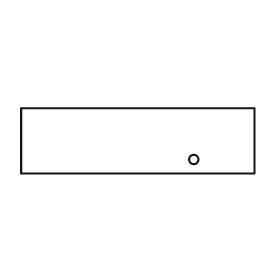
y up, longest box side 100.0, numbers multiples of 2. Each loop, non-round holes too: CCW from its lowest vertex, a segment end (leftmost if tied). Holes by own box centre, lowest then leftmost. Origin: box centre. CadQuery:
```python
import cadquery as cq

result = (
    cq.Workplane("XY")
    .moveTo(-50.0, -14.0)
    .lineTo(50.0, -14.0)
    .lineTo(50.0, 14.0)
    .lineTo(-50.0, 14.0)
    .close()
    .moveTo(24.0, -8.0)
    .circle(2.0)
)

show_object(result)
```